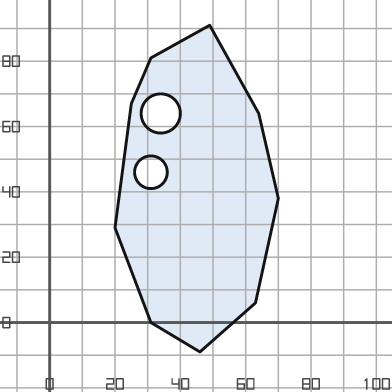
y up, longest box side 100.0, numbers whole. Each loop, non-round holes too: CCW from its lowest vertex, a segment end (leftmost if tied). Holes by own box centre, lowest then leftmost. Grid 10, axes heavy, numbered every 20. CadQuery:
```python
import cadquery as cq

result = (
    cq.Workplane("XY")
    .moveTo(46.0, -9.0)
    .lineTo(63.0, 6.0)
    .lineTo(70.0, 38.0)
    .lineTo(64.0, 64.0)
    .lineTo(49.0, 91.0)
    .lineTo(31.0, 81.0)
    .lineTo(25.0, 67.0)
    .lineTo(20.0, 29.0)
    .lineTo(31.0, 0.0)
    .close()
    .moveTo(31.0, 46.0)
    .circle(5.0)
    .moveTo(34.0, 64.0)
    .circle(6.0)
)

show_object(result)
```